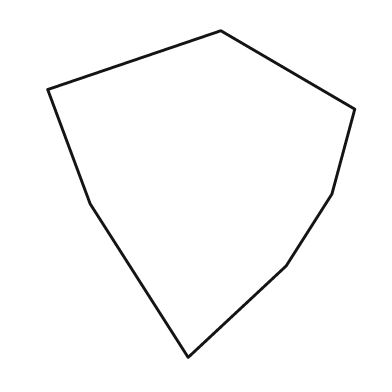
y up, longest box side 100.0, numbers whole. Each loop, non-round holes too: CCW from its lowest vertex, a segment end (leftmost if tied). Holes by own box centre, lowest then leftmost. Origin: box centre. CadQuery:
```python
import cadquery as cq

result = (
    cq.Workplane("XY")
    .moveTo(-4.0, -50.0)
    .lineTo(26.0, -22.0)
    .lineTo(40.0, 0.0)
    .lineTo(47.0, 26.0)
    .lineTo(6.0, 50.0)
    .lineTo(-47.0, 32.0)
    .lineTo(-34.0, -3.0)
    .close()
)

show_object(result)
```